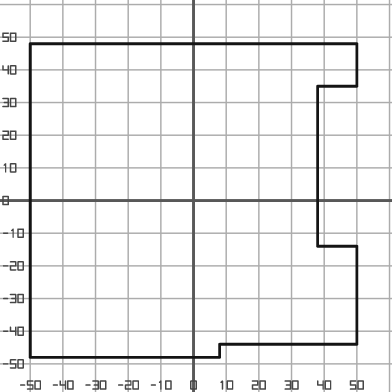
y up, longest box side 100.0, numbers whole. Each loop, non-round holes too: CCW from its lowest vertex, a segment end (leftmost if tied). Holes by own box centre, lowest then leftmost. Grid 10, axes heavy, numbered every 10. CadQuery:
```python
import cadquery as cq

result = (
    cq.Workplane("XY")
    .moveTo(-50.0, -48.0)
    .lineTo(8.0, -48.0)
    .lineTo(8.0, -44.0)
    .lineTo(50.0, -44.0)
    .lineTo(50.0, -14.0)
    .lineTo(38.0, -14.0)
    .lineTo(38.0, 35.0)
    .lineTo(50.0, 35.0)
    .lineTo(50.0, 48.0)
    .lineTo(-50.0, 48.0)
    .close()
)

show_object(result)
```